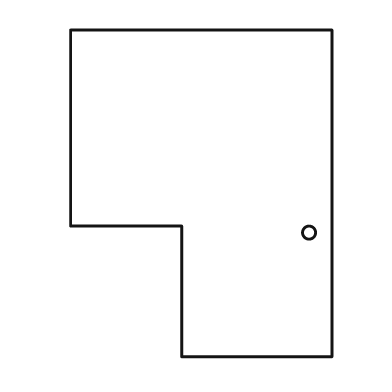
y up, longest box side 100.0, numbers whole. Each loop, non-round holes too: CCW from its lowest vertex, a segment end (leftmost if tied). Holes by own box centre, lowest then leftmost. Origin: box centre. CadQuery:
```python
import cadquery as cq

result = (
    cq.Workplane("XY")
    .moveTo(-6.0, -50.0)
    .lineTo(40.0, -50.0)
    .lineTo(40.0, 50.0)
    .lineTo(-40.0, 50.0)
    .lineTo(-40.0, -10.0)
    .lineTo(-6.0, -10.0)
    .close()
    .moveTo(33.0, -12.0)
    .circle(2.0)
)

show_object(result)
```